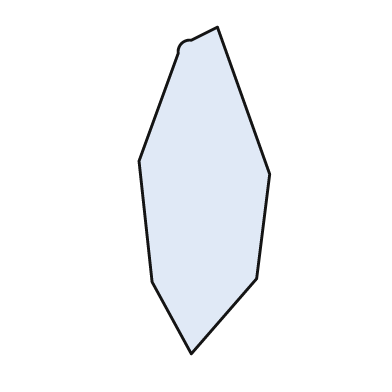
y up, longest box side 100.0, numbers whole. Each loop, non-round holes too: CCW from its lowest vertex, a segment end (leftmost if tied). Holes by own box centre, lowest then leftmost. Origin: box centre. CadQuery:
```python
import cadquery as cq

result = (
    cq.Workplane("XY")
    .moveTo(-4.0, -50.0)
    .lineTo(16.0, -27.0)
    .lineTo(20.0, 5.0)
    .lineTo(4.0, 50.0)
    .lineTo(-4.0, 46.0)
    .threePointArc((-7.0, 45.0), (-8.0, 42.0))
    .lineTo(-20.0, 9.0)
    .lineTo(-16.0, -28.0)
    .close()
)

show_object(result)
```